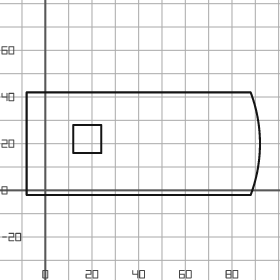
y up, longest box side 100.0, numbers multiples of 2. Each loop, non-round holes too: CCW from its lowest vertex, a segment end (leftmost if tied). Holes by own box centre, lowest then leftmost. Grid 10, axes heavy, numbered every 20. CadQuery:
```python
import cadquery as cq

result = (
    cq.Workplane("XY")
    .moveTo(-8.0, -2.0)
    .lineTo(88.0, -2.0)
    .threePointArc((92.0, 20.0), (88.0, 42.0))
    .lineTo(-8.0, 42.0)
    .close()
    .moveTo(12.0, 16.0)
    .lineTo(24.0, 16.0)
    .lineTo(24.0, 28.0)
    .lineTo(12.0, 28.0)
    .close()
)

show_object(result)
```